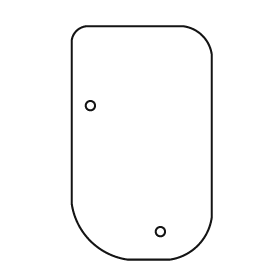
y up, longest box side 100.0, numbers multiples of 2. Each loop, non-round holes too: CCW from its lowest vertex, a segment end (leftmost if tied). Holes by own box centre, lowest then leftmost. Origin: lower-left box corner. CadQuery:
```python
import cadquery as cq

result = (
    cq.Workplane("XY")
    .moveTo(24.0, 0.0)
    .lineTo(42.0, 0.0)
    .threePointArc((54.0, 6.0), (60.0, 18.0))
    .lineTo(60.0, 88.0)
    .threePointArc((56.0, 96.0), (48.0, 100.0))
    .lineTo(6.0, 100.0)
    .threePointArc((2.0, 98.0), (0.0, 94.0))
    .lineTo(0.0, 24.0)
    .threePointArc((8.0, 8.0), (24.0, 0.0))
    .close()
    .moveTo(38.0, 12.0)
    .circle(2.0)
    .moveTo(8.0, 66.0)
    .circle(2.0)
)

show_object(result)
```